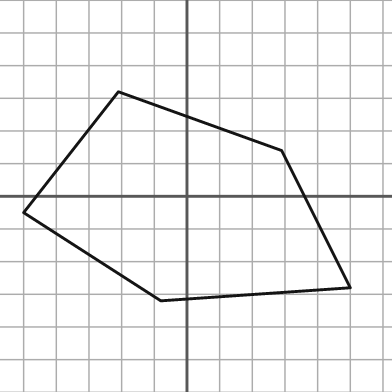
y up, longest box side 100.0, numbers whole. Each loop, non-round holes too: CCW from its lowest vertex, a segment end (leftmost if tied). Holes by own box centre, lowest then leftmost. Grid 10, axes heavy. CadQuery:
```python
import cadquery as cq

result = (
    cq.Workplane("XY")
    .moveTo(-8.0, -32.0)
    .lineTo(50.0, -28.0)
    .lineTo(29.0, 14.0)
    .lineTo(-21.0, 32.0)
    .lineTo(-50.0, -5.0)
    .close()
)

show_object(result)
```